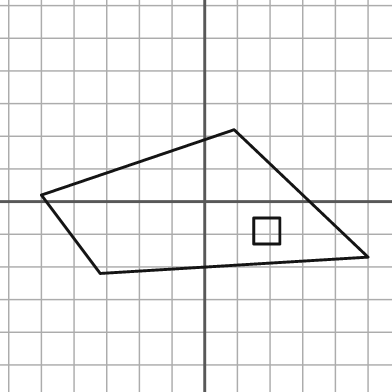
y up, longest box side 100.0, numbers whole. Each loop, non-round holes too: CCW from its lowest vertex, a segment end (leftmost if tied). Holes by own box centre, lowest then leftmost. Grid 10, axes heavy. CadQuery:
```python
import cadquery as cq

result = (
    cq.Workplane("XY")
    .moveTo(-32.0, -22.0)
    .lineTo(50.0, -17.0)
    .lineTo(9.0, 22.0)
    .lineTo(-50.0, 2.0)
    .close()
    .moveTo(15.0, -13.0)
    .lineTo(23.0, -13.0)
    .lineTo(23.0, -5.0)
    .lineTo(15.0, -5.0)
    .close()
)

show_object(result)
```